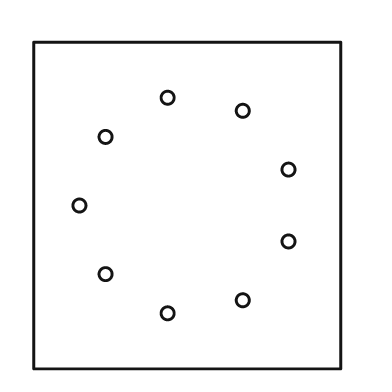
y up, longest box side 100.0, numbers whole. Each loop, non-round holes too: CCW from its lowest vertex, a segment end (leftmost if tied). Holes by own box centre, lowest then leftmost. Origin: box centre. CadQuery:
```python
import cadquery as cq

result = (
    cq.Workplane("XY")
    .moveTo(-47.0, -50.0)
    .lineTo(47.0, -50.0)
    .lineTo(47.0, 50.0)
    .lineTo(-47.0, 50.0)
    .close()
    .moveTo(-6.0, -33.0)
    .circle(2.0)
    .moveTo(17.0, -29.0)
    .circle(2.0)
    .moveTo(-25.0, -21.0)
    .circle(2.0)
    .moveTo(31.0, -11.0)
    .circle(2.0)
    .moveTo(-33.0, 0.0)
    .circle(2.0)
    .moveTo(31.0, 11.0)
    .circle(2.0)
    .moveTo(-25.0, 21.0)
    .circle(2.0)
    .moveTo(17.0, 29.0)
    .circle(2.0)
    .moveTo(-6.0, 33.0)
    .circle(2.0)
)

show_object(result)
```